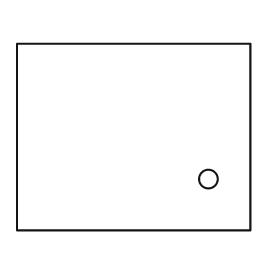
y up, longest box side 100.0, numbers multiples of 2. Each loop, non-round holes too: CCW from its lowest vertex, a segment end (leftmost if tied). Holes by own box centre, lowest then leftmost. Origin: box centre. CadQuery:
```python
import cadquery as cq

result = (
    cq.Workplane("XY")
    .moveTo(-50.0, -40.0)
    .lineTo(50.0, -40.0)
    .lineTo(50.0, 40.0)
    .lineTo(-50.0, 40.0)
    .close()
    .moveTo(32.0, -18.0)
    .circle(4.0)
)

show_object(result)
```